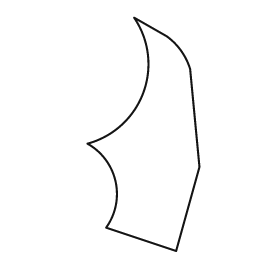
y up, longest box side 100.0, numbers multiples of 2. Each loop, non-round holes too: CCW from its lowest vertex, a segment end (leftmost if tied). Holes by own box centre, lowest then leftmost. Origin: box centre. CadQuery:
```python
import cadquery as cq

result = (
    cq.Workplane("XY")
    .moveTo(14.0, -50.0)
    .lineTo(24.0, -14.0)
    .lineTo(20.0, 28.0)
    .threePointArc((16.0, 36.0), (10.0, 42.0))
    .lineTo(-4.0, 50.0)
    .threePointArc((0.0, 18.0), (-24.0, -4.0))
    .threePointArc((-12.0, -20.0), (-16.0, -40.0))
    .close()
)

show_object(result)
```